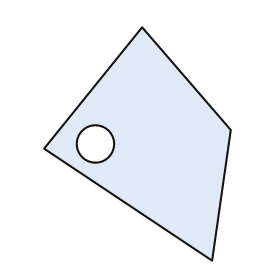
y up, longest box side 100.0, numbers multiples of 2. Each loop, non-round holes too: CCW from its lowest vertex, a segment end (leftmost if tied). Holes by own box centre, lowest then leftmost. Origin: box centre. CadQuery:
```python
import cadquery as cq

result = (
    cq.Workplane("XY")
    .moveTo(32.0, -50.0)
    .lineTo(40.0, 6.0)
    .lineTo(2.0, 50.0)
    .lineTo(-40.0, -2.0)
    .close()
    .moveTo(-18.0, 0.0)
    .circle(8.0)
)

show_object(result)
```